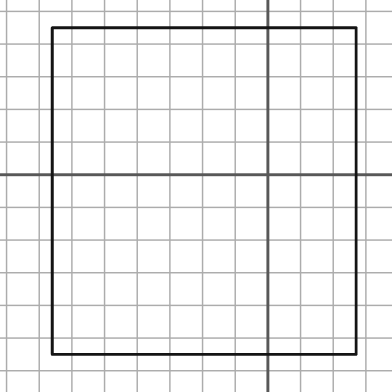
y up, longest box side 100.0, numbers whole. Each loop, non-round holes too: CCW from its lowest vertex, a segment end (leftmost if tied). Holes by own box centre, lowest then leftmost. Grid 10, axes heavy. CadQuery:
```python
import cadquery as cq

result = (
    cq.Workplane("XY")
    .moveTo(-66.0, -55.0)
    .lineTo(27.0, -55.0)
    .lineTo(27.0, 45.0)
    .lineTo(-66.0, 45.0)
    .close()
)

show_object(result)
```